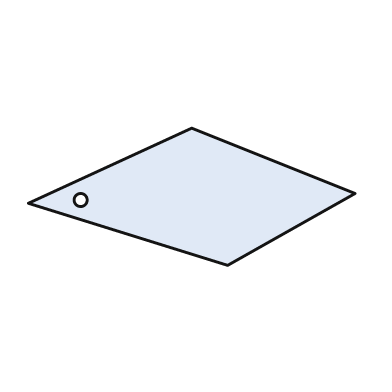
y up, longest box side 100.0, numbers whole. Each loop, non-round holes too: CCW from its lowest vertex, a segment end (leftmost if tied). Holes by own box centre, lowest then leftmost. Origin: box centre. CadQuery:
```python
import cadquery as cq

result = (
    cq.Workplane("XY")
    .moveTo(11.0, -21.0)
    .lineTo(50.0, 1.0)
    .lineTo(0.0, 21.0)
    .lineTo(-50.0, -2.0)
    .close()
    .moveTo(-34.0, -1.0)
    .circle(2.0)
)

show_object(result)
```